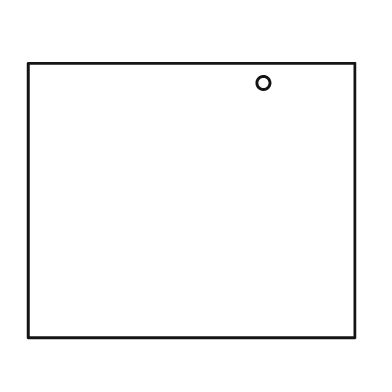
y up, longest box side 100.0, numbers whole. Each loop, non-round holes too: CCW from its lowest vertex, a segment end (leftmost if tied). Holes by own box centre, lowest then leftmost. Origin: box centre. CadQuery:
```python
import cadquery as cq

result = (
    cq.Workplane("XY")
    .moveTo(-50.0, -42.0)
    .lineTo(50.0, -42.0)
    .lineTo(50.0, 42.0)
    .lineTo(-50.0, 42.0)
    .close()
    .moveTo(22.0, 36.0)
    .circle(2.0)
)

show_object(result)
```